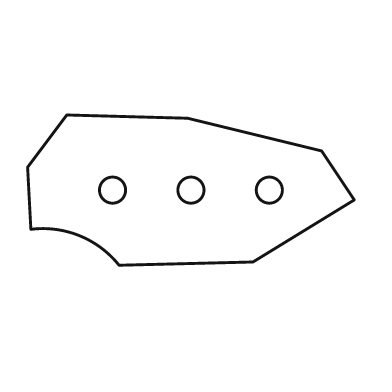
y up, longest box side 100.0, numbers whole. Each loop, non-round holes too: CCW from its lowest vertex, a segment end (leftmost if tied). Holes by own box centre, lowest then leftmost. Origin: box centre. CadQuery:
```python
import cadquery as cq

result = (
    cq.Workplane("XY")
    .moveTo(-22.0, -23.0)
    .lineTo(19.0, -22.0)
    .lineTo(50.0, -3.0)
    .lineTo(40.0, 12.0)
    .lineTo(-1.0, 22.0)
    .lineTo(-38.0, 23.0)
    .lineTo(-50.0, 7.0)
    .lineTo(-49.0, -12.0)
    .threePointArc((-34.0, -14.0), (-22.0, -23.0))
    .close()
    .moveTo(-24.0, 0.0)
    .circle(4.0)
    .moveTo(0.0, 0.0)
    .circle(4.0)
    .moveTo(24.0, 0.0)
    .circle(4.0)
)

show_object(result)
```